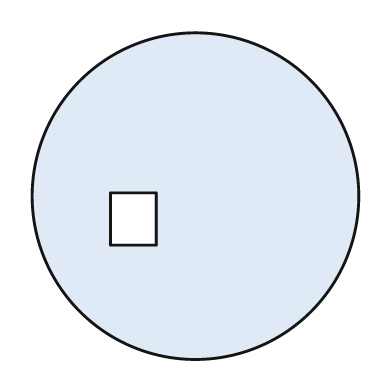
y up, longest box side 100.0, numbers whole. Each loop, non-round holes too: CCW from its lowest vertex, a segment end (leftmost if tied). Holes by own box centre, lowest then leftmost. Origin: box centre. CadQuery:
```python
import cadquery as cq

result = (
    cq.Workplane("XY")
    .moveTo(0.0, 0.0)
    .circle(50.0)
    .moveTo(-26.0, -15.0)
    .lineTo(-12.0, -15.0)
    .lineTo(-12.0, 1.0)
    .lineTo(-26.0, 1.0)
    .close()
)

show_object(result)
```